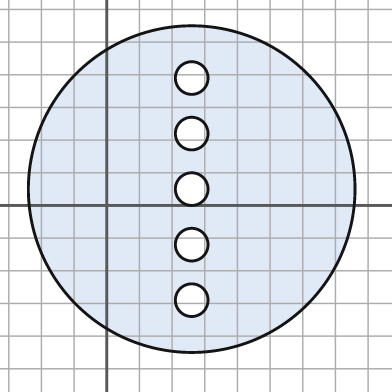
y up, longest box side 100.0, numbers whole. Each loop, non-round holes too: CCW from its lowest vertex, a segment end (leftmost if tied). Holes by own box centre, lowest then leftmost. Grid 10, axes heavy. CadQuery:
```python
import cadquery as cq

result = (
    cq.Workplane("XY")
    .moveTo(26.0, 5.0)
    .circle(50.0)
    .moveTo(26.0, -29.0)
    .circle(5.0)
    .moveTo(26.0, -12.0)
    .circle(5.0)
    .moveTo(26.0, 5.0)
    .circle(5.0)
    .moveTo(26.0, 22.0)
    .circle(5.0)
    .moveTo(26.0, 39.0)
    .circle(5.0)
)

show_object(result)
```